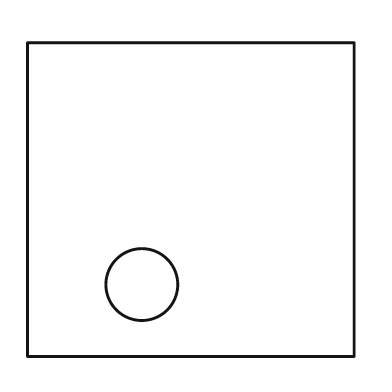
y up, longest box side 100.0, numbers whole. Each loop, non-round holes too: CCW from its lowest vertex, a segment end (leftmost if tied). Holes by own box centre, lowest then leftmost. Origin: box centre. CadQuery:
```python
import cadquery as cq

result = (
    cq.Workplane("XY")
    .moveTo(-50.0, -48.0)
    .lineTo(50.0, -48.0)
    .lineTo(50.0, 48.0)
    .lineTo(-50.0, 48.0)
    .close()
    .moveTo(-15.0, -26.0)
    .circle(11.0)
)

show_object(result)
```